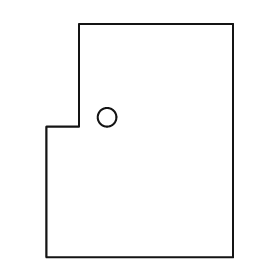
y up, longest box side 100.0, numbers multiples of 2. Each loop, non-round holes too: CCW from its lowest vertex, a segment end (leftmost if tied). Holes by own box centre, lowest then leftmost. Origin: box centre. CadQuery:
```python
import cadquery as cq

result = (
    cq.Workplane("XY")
    .moveTo(-40.0, -50.0)
    .lineTo(40.0, -50.0)
    .lineTo(40.0, 50.0)
    .lineTo(-26.0, 50.0)
    .lineTo(-26.0, 6.0)
    .lineTo(-40.0, 6.0)
    .close()
    .moveTo(-14.0, 10.0)
    .circle(4.0)
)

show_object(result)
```